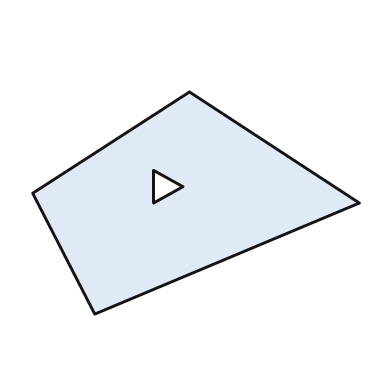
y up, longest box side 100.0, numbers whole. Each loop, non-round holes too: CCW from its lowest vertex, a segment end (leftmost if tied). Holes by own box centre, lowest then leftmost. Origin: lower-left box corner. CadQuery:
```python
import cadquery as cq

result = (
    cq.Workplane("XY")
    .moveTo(19.0, 0.0)
    .lineTo(100.0, 34.0)
    .lineTo(48.0, 68.0)
    .lineTo(0.0, 37.0)
    .close()
    .moveTo(37.0, 34.0)
    .lineTo(46.0, 39.0)
    .lineTo(37.0, 44.0)
    .close()
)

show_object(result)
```